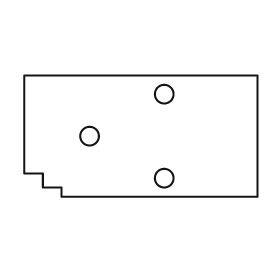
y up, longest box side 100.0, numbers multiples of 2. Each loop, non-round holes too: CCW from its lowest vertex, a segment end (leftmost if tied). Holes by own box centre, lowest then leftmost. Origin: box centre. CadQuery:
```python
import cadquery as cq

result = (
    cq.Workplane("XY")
    .moveTo(-34.0, -26.0)
    .lineTo(50.0, -26.0)
    .lineTo(50.0, 26.0)
    .lineTo(-50.0, 26.0)
    .lineTo(-50.0, -16.0)
    .lineTo(-42.0, -16.0)
    .lineTo(-42.0, -22.0)
    .lineTo(-34.0, -22.0)
    .close()
    .moveTo(10.0, -18.0)
    .circle(4.0)
    .moveTo(-22.0, 0.0)
    .circle(4.0)
    .moveTo(10.0, 18.0)
    .circle(4.0)
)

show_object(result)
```